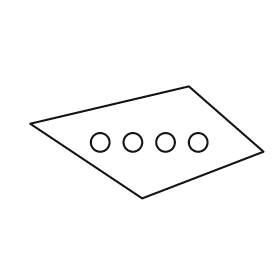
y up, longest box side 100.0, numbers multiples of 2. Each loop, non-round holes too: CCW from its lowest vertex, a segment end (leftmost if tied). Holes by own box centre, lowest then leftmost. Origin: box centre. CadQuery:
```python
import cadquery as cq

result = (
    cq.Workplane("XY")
    .moveTo(-2.0, -24.0)
    .lineTo(50.0, -4.0)
    .lineTo(18.0, 24.0)
    .lineTo(-50.0, 8.0)
    .close()
    .moveTo(-20.0, 0.0)
    .circle(4.0)
    .moveTo(-6.0, 0.0)
    .circle(4.0)
    .moveTo(8.0, 0.0)
    .circle(4.0)
    .moveTo(22.0, 0.0)
    .circle(4.0)
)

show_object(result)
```